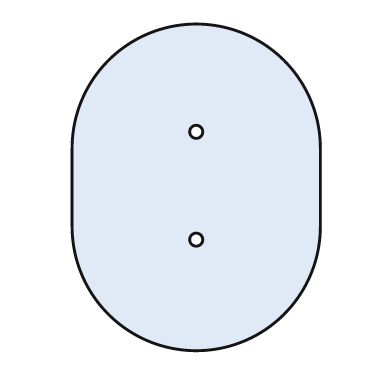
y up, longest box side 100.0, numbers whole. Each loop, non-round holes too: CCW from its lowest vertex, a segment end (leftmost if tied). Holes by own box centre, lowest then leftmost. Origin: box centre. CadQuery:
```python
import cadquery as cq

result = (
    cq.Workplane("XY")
    .moveTo(-38.0, -12.0)
    .threePointArc((0.0, -50.0), (38.0, -12.0))
    .lineTo(38.0, 12.0)
    .threePointArc((0.0, 50.0), (-38.0, 12.0))
    .close()
    .moveTo(0.0, -16.0)
    .circle(2.0)
    .moveTo(0.0, 17.0)
    .circle(2.0)
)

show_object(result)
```